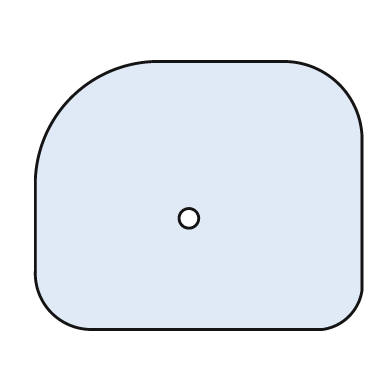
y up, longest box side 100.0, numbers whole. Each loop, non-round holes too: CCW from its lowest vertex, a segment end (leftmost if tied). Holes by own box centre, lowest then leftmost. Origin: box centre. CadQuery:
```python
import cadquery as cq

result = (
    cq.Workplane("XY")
    .moveTo(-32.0, -41.0)
    .lineTo(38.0, -41.0)
    .threePointArc((46.0, -37.0), (50.0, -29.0))
    .lineTo(50.0, 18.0)
    .threePointArc((43.0, 34.0), (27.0, 41.0))
    .lineTo(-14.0, 41.0)
    .threePointArc((-39.0, 30.0), (-50.0, 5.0))
    .lineTo(-50.0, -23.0)
    .threePointArc((-45.0, -36.0), (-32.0, -41.0))
    .close()
    .moveTo(-3.0, -7.0)
    .circle(3.0)
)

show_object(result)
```